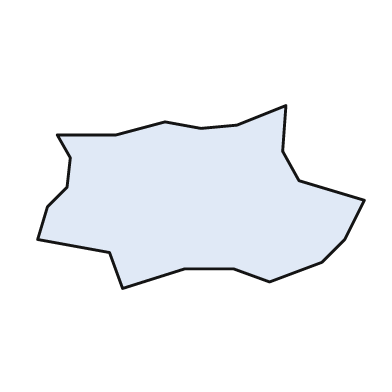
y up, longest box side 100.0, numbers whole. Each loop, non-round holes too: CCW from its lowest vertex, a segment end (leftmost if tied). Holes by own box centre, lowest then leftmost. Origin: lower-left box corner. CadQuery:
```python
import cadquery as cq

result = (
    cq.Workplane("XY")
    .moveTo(26.0, 0.0)
    .lineTo(45.0, 6.0)
    .lineTo(60.0, 6.0)
    .lineTo(71.0, 2.0)
    .lineTo(87.0, 8.0)
    .lineTo(94.0, 15.0)
    .lineTo(100.0, 27.0)
    .lineTo(80.0, 33.0)
    .lineTo(75.0, 42.0)
    .lineTo(76.0, 56.0)
    .lineTo(61.0, 50.0)
    .lineTo(50.0, 49.0)
    .lineTo(39.0, 51.0)
    .lineTo(24.0, 47.0)
    .lineTo(6.0, 47.0)
    .lineTo(10.0, 40.0)
    .lineTo(9.0, 31.0)
    .lineTo(3.0, 25.0)
    .lineTo(0.0, 15.0)
    .lineTo(22.0, 11.0)
    .close()
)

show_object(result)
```